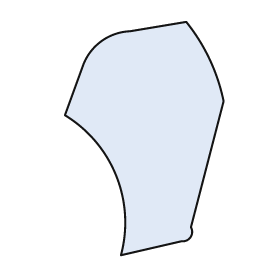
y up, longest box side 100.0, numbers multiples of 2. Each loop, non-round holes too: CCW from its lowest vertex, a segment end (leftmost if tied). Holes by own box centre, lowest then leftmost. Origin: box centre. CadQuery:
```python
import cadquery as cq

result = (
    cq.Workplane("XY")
    .moveTo(-10.0, -50.0)
    .lineTo(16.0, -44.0)
    .threePointArc((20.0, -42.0), (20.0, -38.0))
    .lineTo(34.0, 16.0)
    .threePointArc((28.0, 34.0), (18.0, 50.0))
    .lineTo(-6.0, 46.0)
    .threePointArc((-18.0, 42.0), (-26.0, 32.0))
    .lineTo(-34.0, 10.0)
    .threePointArc((-12.0, -16.0), (-10.0, -50.0))
    .close()
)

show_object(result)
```